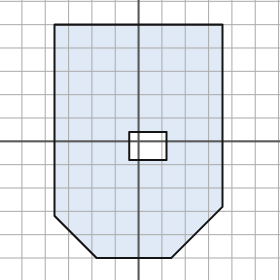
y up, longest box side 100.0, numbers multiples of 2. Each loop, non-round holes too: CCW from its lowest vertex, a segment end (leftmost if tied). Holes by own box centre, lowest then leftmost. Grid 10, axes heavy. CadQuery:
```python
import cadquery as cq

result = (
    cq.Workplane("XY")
    .moveTo(-18.0, -50.0)
    .lineTo(14.0, -50.0)
    .lineTo(36.0, -28.0)
    .lineTo(36.0, 50.0)
    .lineTo(-36.0, 50.0)
    .lineTo(-36.0, -32.0)
    .close()
    .moveTo(-4.0, -8.0)
    .lineTo(12.0, -8.0)
    .lineTo(12.0, 4.0)
    .lineTo(-4.0, 4.0)
    .close()
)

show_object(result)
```